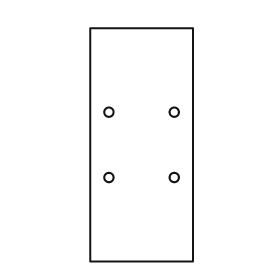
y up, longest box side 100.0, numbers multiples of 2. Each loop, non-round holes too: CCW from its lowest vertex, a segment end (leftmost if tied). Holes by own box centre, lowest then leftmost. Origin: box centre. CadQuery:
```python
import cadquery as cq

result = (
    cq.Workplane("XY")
    .moveTo(-22.0, -50.0)
    .lineTo(22.0, -50.0)
    .lineTo(22.0, 50.0)
    .lineTo(-22.0, 50.0)
    .close()
    .moveTo(-14.0, -14.0)
    .circle(2.0)
    .moveTo(14.0, -14.0)
    .circle(2.0)
    .moveTo(-14.0, 14.0)
    .circle(2.0)
    .moveTo(14.0, 14.0)
    .circle(2.0)
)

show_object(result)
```